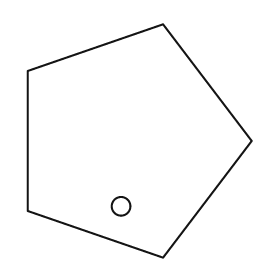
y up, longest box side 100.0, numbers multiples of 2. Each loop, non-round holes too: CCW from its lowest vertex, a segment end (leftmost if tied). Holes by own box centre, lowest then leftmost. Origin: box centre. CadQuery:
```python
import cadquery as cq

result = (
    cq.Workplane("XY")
    .moveTo(10.0, -50.0)
    .lineTo(48.0, 0.0)
    .lineTo(10.0, 50.0)
    .lineTo(-48.0, 30.0)
    .lineTo(-48.0, -30.0)
    .close()
    .moveTo(-8.0, -28.0)
    .circle(4.0)
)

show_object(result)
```